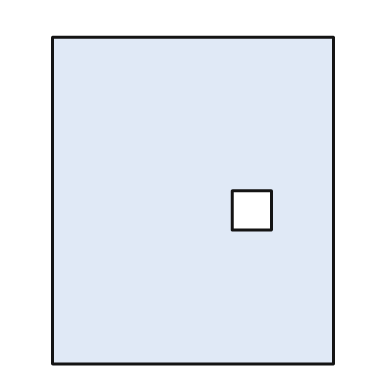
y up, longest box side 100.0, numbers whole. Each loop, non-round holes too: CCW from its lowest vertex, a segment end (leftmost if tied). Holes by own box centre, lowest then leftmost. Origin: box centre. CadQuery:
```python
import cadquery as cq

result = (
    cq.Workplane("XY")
    .moveTo(-43.0, -50.0)
    .lineTo(43.0, -50.0)
    .lineTo(43.0, 50.0)
    .lineTo(-43.0, 50.0)
    .close()
    .moveTo(12.0, -9.0)
    .lineTo(24.0, -9.0)
    .lineTo(24.0, 3.0)
    .lineTo(12.0, 3.0)
    .close()
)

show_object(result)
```